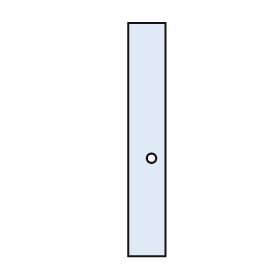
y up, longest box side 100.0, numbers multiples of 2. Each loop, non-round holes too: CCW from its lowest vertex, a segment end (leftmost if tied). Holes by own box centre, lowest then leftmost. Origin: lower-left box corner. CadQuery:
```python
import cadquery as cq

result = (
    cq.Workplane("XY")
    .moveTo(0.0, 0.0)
    .lineTo(16.0, 0.0)
    .lineTo(16.0, 100.0)
    .lineTo(0.0, 100.0)
    .close()
    .moveTo(10.0, 42.0)
    .circle(2.0)
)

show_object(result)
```